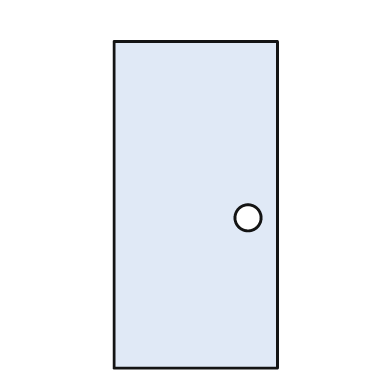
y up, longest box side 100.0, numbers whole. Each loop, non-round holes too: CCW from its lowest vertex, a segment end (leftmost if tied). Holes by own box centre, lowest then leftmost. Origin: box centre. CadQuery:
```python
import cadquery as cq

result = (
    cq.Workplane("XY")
    .moveTo(-25.0, -50.0)
    .lineTo(25.0, -50.0)
    .lineTo(25.0, 50.0)
    .lineTo(-25.0, 50.0)
    .close()
    .moveTo(16.0, -4.0)
    .circle(4.0)
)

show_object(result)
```